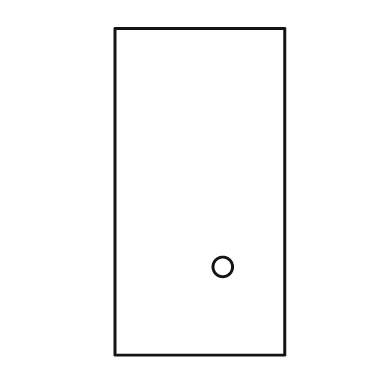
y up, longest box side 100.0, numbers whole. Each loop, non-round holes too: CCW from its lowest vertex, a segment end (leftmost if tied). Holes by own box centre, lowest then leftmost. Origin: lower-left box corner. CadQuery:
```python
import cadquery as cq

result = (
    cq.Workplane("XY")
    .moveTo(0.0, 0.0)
    .lineTo(52.0, 0.0)
    .lineTo(52.0, 100.0)
    .lineTo(0.0, 100.0)
    .close()
    .moveTo(33.0, 27.0)
    .circle(3.0)
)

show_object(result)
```